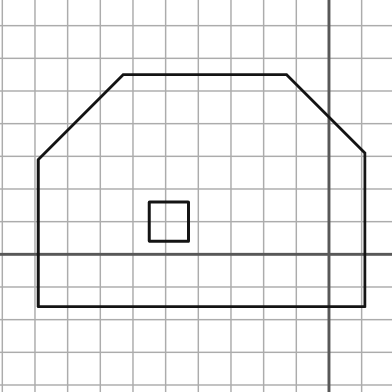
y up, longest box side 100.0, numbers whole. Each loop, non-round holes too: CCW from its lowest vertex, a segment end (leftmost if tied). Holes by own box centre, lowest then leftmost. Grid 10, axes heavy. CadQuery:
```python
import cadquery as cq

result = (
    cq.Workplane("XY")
    .moveTo(-89.0, -16.0)
    .lineTo(11.0, -16.0)
    .lineTo(11.0, 31.0)
    .lineTo(-13.0, 55.0)
    .lineTo(-63.0, 55.0)
    .lineTo(-89.0, 29.0)
    .close()
    .moveTo(-55.0, 4.0)
    .lineTo(-43.0, 4.0)
    .lineTo(-43.0, 16.0)
    .lineTo(-55.0, 16.0)
    .close()
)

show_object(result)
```